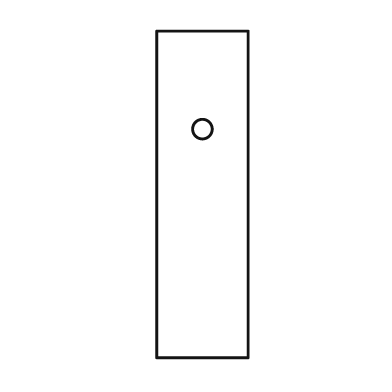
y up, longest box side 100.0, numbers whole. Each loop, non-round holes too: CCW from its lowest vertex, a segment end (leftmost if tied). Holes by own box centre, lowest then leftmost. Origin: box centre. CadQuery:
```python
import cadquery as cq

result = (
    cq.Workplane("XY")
    .moveTo(-14.0, -50.0)
    .lineTo(14.0, -50.0)
    .lineTo(14.0, 50.0)
    .lineTo(-14.0, 50.0)
    .close()
    .moveTo(0.0, 20.0)
    .circle(3.0)
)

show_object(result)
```